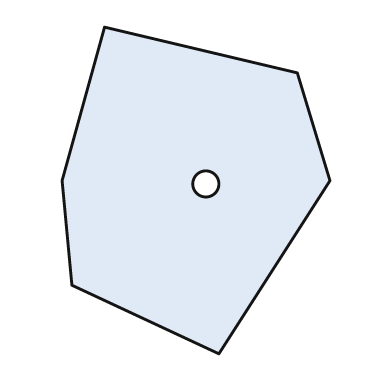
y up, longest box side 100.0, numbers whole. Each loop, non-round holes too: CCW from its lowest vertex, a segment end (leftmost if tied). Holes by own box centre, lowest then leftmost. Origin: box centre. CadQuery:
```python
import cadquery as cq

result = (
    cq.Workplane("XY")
    .moveTo(7.0, -50.0)
    .lineTo(41.0, 3.0)
    .lineTo(31.0, 36.0)
    .lineTo(-28.0, 50.0)
    .lineTo(-41.0, 3.0)
    .lineTo(-38.0, -29.0)
    .close()
    .moveTo(3.0, 2.0)
    .circle(4.0)
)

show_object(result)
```